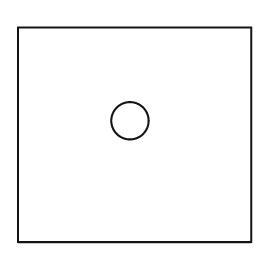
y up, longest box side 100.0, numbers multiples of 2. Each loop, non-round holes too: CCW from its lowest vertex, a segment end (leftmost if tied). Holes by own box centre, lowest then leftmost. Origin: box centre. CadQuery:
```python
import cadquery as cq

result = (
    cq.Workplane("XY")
    .moveTo(-50.0, -46.0)
    .lineTo(50.0, -46.0)
    .lineTo(50.0, 46.0)
    .lineTo(-50.0, 46.0)
    .close()
    .moveTo(-2.0, 6.0)
    .circle(8.0)
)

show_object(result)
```